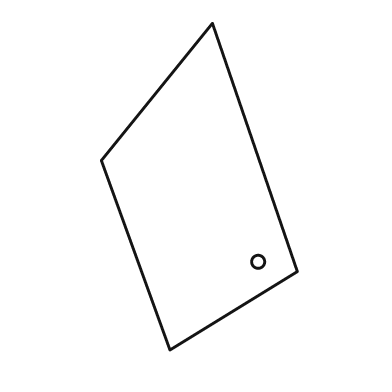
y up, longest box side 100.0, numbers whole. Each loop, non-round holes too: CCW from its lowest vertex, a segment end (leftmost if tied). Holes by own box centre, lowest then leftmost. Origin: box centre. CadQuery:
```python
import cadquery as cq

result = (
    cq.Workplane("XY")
    .moveTo(-9.0, -50.0)
    .lineTo(30.0, -26.0)
    .lineTo(4.0, 50.0)
    .lineTo(-30.0, 8.0)
    .close()
    .moveTo(18.0, -23.0)
    .circle(2.0)
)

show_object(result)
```